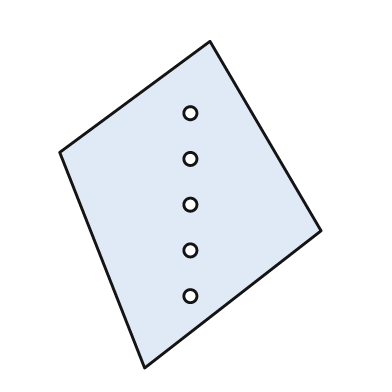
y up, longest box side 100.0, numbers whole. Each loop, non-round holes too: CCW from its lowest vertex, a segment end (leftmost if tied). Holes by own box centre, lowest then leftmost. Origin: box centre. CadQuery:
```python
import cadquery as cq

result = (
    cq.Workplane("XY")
    .moveTo(-14.0, -50.0)
    .lineTo(40.0, -8.0)
    .lineTo(6.0, 50.0)
    .lineTo(-40.0, 16.0)
    .close()
    .moveTo(0.0, -28.0)
    .circle(2.0)
    .moveTo(0.0, -14.0)
    .circle(2.0)
    .moveTo(0.0, 0.0)
    .circle(2.0)
    .moveTo(0.0, 14.0)
    .circle(2.0)
    .moveTo(0.0, 28.0)
    .circle(2.0)
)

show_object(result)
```